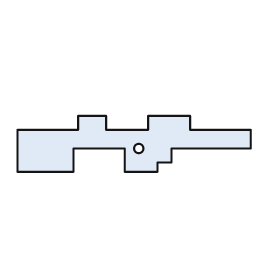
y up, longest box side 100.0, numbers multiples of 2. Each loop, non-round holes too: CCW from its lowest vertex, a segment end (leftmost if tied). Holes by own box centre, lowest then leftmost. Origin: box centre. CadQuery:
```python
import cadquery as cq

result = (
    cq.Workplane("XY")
    .moveTo(-50.0, -12.0)
    .lineTo(-26.0, -12.0)
    .lineTo(-26.0, -2.0)
    .lineTo(-4.0, -2.0)
    .lineTo(-4.0, -12.0)
    .lineTo(10.0, -12.0)
    .lineTo(10.0, -8.0)
    .lineTo(16.0, -8.0)
    .lineTo(16.0, -2.0)
    .lineTo(50.0, -2.0)
    .lineTo(50.0, 6.0)
    .lineTo(24.0, 6.0)
    .lineTo(24.0, 12.0)
    .lineTo(6.0, 12.0)
    .lineTo(6.0, 6.0)
    .lineTo(-12.0, 6.0)
    .lineTo(-12.0, 12.0)
    .lineTo(-24.0, 12.0)
    .lineTo(-24.0, 6.0)
    .lineTo(-50.0, 6.0)
    .close()
    .moveTo(2.0, -2.0)
    .circle(2.0)
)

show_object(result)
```